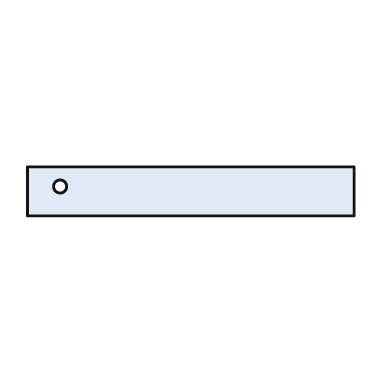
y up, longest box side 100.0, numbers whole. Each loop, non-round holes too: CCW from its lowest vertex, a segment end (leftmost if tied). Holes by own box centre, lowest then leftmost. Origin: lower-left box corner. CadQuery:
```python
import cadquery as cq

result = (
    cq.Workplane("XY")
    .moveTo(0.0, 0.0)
    .lineTo(100.0, 0.0)
    .lineTo(100.0, 15.0)
    .lineTo(0.0, 15.0)
    .close()
    .moveTo(10.0, 9.0)
    .circle(2.0)
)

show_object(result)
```